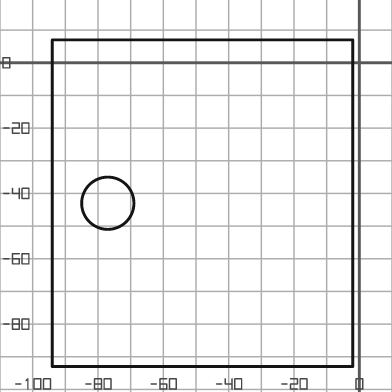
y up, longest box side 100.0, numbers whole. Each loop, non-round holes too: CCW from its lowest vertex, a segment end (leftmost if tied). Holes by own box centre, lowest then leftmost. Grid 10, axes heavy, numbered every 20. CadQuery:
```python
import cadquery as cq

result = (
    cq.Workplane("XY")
    .moveTo(-94.0, -93.0)
    .lineTo(-2.0, -93.0)
    .lineTo(-2.0, 7.0)
    .lineTo(-94.0, 7.0)
    .close()
    .moveTo(-77.0, -43.0)
    .circle(8.0)
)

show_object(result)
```